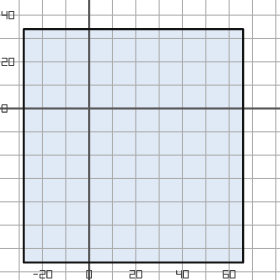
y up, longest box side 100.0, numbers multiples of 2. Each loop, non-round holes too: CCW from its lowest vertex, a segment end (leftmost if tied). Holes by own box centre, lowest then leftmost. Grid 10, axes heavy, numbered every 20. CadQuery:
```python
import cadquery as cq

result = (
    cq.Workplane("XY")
    .moveTo(-28.0, -66.0)
    .lineTo(66.0, -66.0)
    .lineTo(66.0, 34.0)
    .lineTo(-28.0, 34.0)
    .close()
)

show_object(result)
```